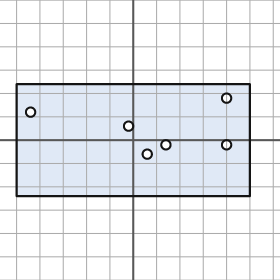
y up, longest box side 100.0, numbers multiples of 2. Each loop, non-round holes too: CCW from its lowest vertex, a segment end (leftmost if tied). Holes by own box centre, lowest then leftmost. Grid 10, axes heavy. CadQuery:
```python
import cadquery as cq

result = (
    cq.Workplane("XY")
    .moveTo(-50.0, -24.0)
    .lineTo(50.0, -24.0)
    .lineTo(50.0, 24.0)
    .lineTo(-50.0, 24.0)
    .close()
    .moveTo(6.0, -6.0)
    .circle(2.0)
    .moveTo(14.0, -2.0)
    .circle(2.0)
    .moveTo(40.0, -2.0)
    .circle(2.0)
    .moveTo(-2.0, 6.0)
    .circle(2.0)
    .moveTo(-44.0, 12.0)
    .circle(2.0)
    .moveTo(40.0, 18.0)
    .circle(2.0)
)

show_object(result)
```